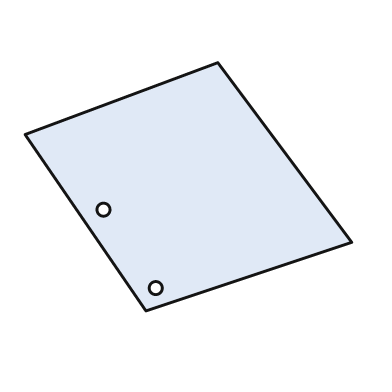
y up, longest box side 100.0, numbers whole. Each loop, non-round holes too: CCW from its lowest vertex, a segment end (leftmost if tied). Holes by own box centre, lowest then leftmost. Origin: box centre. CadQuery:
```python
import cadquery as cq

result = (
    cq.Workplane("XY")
    .moveTo(-13.0, -38.0)
    .lineTo(50.0, -17.0)
    .lineTo(9.0, 38.0)
    .lineTo(-50.0, 16.0)
    .close()
    .moveTo(-10.0, -31.0)
    .circle(2.0)
    .moveTo(-26.0, -7.0)
    .circle(2.0)
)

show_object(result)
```